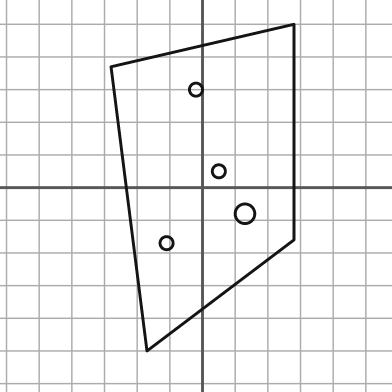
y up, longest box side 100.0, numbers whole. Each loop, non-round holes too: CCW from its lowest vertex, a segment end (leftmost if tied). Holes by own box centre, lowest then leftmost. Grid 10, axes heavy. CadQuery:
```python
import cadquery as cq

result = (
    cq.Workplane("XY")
    .moveTo(-17.0, -50.0)
    .lineTo(28.0, -16.0)
    .lineTo(28.0, 50.0)
    .lineTo(-28.0, 37.0)
    .close()
    .moveTo(-11.0, -17.0)
    .circle(2.0)
    .moveTo(13.0, -8.0)
    .circle(3.0)
    .moveTo(5.0, 5.0)
    .circle(2.0)
    .moveTo(-2.0, 30.0)
    .circle(2.0)
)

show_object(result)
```